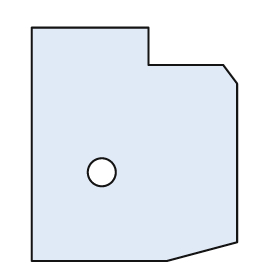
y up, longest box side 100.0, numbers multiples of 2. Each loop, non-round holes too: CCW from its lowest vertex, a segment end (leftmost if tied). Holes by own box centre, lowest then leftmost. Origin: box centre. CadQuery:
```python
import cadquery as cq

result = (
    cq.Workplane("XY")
    .moveTo(-44.0, -50.0)
    .lineTo(14.0, -50.0)
    .lineTo(44.0, -42.0)
    .lineTo(44.0, 26.0)
    .lineTo(38.0, 34.0)
    .lineTo(6.0, 34.0)
    .lineTo(6.0, 50.0)
    .lineTo(-44.0, 50.0)
    .close()
    .moveTo(-14.0, -12.0)
    .circle(6.0)
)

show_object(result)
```